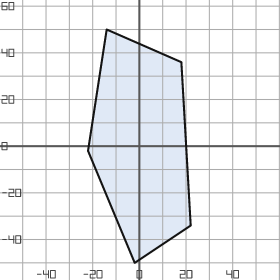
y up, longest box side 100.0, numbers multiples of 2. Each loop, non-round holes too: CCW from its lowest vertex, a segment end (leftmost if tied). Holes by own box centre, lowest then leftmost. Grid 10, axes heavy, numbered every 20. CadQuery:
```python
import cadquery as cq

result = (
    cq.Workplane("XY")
    .moveTo(-2.0, -50.0)
    .lineTo(22.0, -34.0)
    .lineTo(18.0, 36.0)
    .lineTo(-14.0, 50.0)
    .lineTo(-22.0, -2.0)
    .close()
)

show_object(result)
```